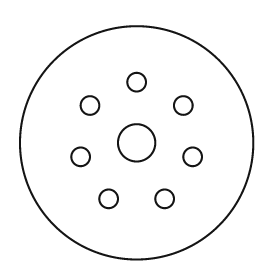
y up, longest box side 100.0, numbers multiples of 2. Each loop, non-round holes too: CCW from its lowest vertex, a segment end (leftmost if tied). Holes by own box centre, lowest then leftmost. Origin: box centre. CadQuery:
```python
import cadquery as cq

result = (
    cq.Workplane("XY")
    .moveTo(0.0, 0.0)
    .circle(50.0)
    .moveTo(-12.0, -24.0)
    .circle(4.0)
    .moveTo(12.0, -24.0)
    .circle(4.0)
    .moveTo(-24.0, -6.0)
    .circle(4.0)
    .moveTo(24.0, -6.0)
    .circle(4.0)
    .moveTo(0.0, 0.0)
    .circle(8.0)
    .moveTo(-20.0, 16.0)
    .circle(4.0)
    .moveTo(20.0, 16.0)
    .circle(4.0)
    .moveTo(0.0, 26.0)
    .circle(4.0)
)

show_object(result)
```